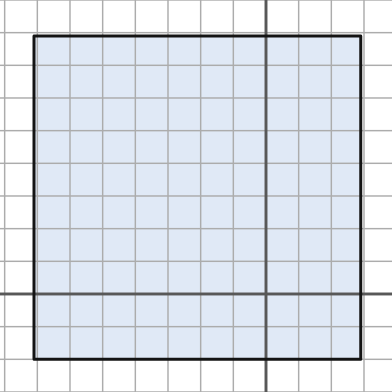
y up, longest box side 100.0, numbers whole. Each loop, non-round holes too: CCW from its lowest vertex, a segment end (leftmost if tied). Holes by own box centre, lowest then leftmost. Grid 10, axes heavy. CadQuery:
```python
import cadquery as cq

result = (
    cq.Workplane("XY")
    .moveTo(-71.0, -20.0)
    .lineTo(29.0, -20.0)
    .lineTo(29.0, 79.0)
    .lineTo(-71.0, 79.0)
    .close()
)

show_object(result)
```